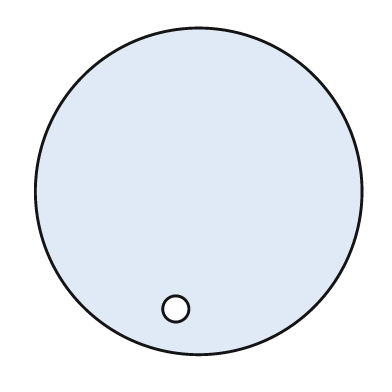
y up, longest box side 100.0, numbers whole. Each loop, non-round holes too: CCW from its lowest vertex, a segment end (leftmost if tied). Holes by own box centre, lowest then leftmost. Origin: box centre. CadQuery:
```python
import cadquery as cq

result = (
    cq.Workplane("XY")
    .moveTo(0.0, 0.0)
    .circle(50.0)
    .moveTo(-7.0, -36.0)
    .circle(4.0)
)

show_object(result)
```